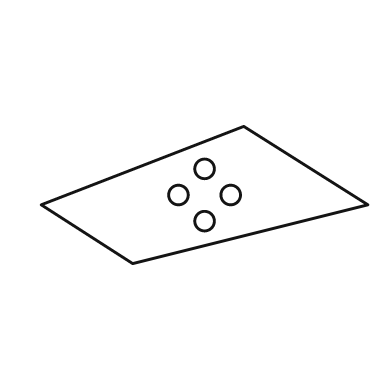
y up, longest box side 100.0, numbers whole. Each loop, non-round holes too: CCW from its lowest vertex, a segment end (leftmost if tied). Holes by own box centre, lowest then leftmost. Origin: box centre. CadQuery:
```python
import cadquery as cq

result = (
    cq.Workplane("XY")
    .moveTo(-22.0, -21.0)
    .lineTo(50.0, -3.0)
    .lineTo(12.0, 21.0)
    .lineTo(-50.0, -3.0)
    .close()
    .moveTo(0.0, -8.0)
    .circle(3.0)
    .moveTo(-8.0, 0.0)
    .circle(3.0)
    .moveTo(8.0, 0.0)
    .circle(3.0)
    .moveTo(0.0, 8.0)
    .circle(3.0)
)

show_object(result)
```